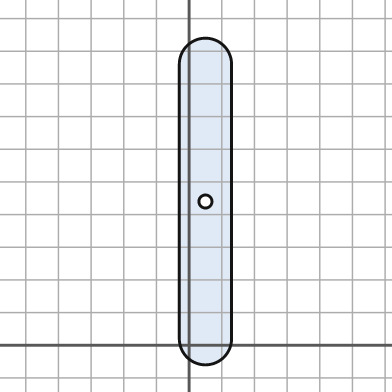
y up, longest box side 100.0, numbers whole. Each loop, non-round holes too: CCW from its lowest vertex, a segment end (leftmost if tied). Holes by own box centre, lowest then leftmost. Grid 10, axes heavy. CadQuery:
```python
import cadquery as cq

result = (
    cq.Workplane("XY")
    .moveTo(-3.0, 2.0)
    .threePointArc((5.0, -6.0), (13.0, 2.0))
    .lineTo(13.0, 86.0)
    .threePointArc((5.0, 94.0), (-3.0, 86.0))
    .close()
    .moveTo(5.0, 44.0)
    .circle(2.0)
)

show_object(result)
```